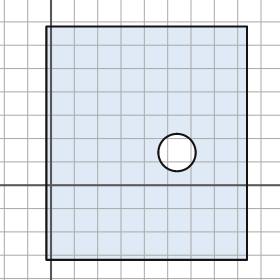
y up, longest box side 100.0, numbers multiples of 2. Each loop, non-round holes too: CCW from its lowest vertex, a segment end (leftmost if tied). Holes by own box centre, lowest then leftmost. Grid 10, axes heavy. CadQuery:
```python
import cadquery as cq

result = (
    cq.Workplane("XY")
    .moveTo(-2.0, -32.0)
    .lineTo(84.0, -32.0)
    .lineTo(84.0, 68.0)
    .lineTo(-2.0, 68.0)
    .close()
    .moveTo(54.0, 14.0)
    .circle(8.0)
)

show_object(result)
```